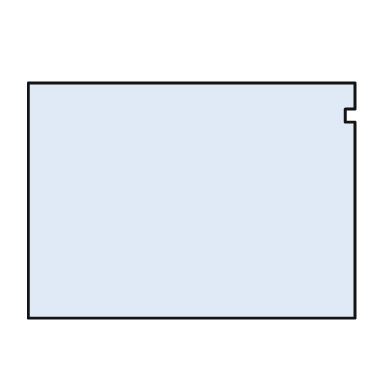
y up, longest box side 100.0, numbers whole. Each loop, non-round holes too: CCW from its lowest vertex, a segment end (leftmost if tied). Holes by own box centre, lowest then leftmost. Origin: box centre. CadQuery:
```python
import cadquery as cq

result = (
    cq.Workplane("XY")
    .moveTo(-50.0, -36.0)
    .lineTo(50.0, -36.0)
    .lineTo(50.0, 24.0)
    .lineTo(47.0, 24.0)
    .lineTo(47.0, 28.0)
    .lineTo(50.0, 28.0)
    .lineTo(50.0, 36.0)
    .lineTo(-50.0, 36.0)
    .close()
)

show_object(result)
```